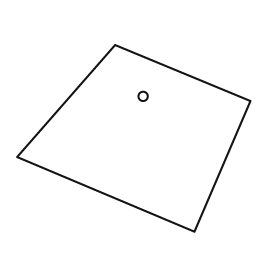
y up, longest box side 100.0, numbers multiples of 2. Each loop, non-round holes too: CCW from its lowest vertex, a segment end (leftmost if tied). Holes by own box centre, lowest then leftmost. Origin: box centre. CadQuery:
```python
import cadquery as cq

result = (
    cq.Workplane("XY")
    .moveTo(26.0, -40.0)
    .lineTo(50.0, 16.0)
    .lineTo(-8.0, 40.0)
    .lineTo(-50.0, -8.0)
    .close()
    .moveTo(4.0, 18.0)
    .circle(2.0)
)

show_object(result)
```